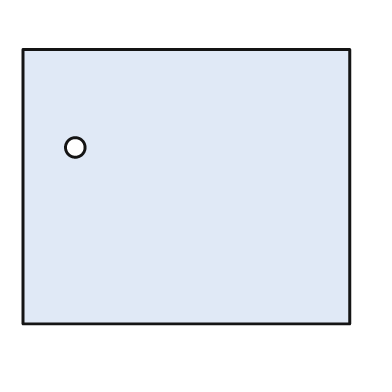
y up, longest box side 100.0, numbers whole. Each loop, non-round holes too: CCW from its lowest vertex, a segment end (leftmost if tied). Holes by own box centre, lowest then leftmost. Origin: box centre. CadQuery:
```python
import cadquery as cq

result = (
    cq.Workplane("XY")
    .moveTo(-50.0, -42.0)
    .lineTo(50.0, -42.0)
    .lineTo(50.0, 42.0)
    .lineTo(-50.0, 42.0)
    .close()
    .moveTo(-34.0, 12.0)
    .circle(3.0)
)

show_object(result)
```